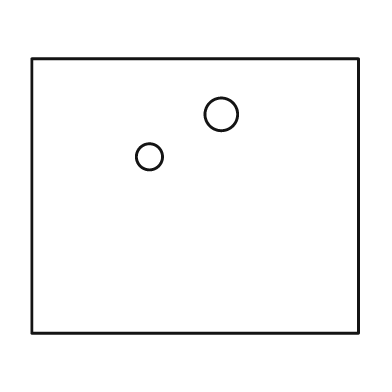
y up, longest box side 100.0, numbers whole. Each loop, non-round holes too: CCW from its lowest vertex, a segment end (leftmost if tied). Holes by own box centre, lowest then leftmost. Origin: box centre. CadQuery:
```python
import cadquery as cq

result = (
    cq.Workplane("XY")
    .moveTo(-50.0, -42.0)
    .lineTo(50.0, -42.0)
    .lineTo(50.0, 42.0)
    .lineTo(-50.0, 42.0)
    .close()
    .moveTo(-14.0, 12.0)
    .circle(4.0)
    .moveTo(8.0, 25.0)
    .circle(5.0)
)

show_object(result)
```